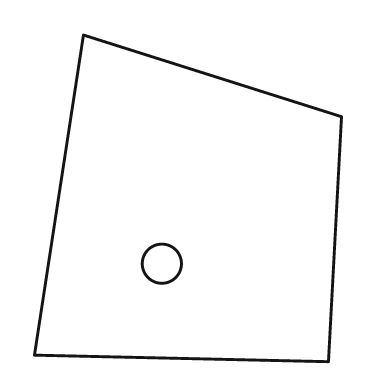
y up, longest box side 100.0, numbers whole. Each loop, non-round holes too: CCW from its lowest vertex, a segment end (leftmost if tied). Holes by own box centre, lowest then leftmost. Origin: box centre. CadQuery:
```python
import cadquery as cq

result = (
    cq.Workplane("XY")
    .moveTo(43.0, -50.0)
    .lineTo(47.0, 25.0)
    .lineTo(-32.0, 50.0)
    .lineTo(-47.0, -48.0)
    .close()
    .moveTo(-8.0, -20.0)
    .circle(6.0)
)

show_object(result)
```